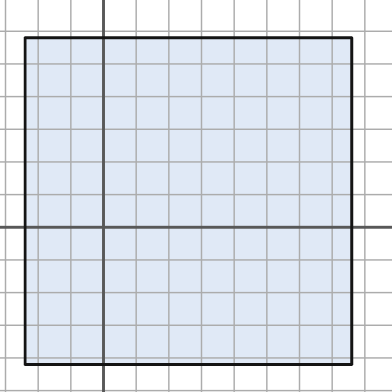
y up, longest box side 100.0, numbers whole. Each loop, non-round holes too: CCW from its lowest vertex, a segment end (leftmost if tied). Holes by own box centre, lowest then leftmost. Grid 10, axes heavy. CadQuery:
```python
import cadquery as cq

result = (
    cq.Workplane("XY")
    .moveTo(-24.0, -42.0)
    .lineTo(76.0, -42.0)
    .lineTo(76.0, 58.0)
    .lineTo(-24.0, 58.0)
    .close()
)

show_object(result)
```